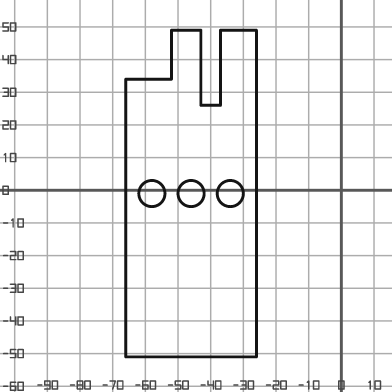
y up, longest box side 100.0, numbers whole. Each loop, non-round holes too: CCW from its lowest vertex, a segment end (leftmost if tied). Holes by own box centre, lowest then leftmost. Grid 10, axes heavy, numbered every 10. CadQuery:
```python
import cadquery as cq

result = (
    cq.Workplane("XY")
    .moveTo(-66.0, -51.0)
    .lineTo(-26.0, -51.0)
    .lineTo(-26.0, 49.0)
    .lineTo(-37.0, 49.0)
    .lineTo(-37.0, 26.0)
    .lineTo(-43.0, 26.0)
    .lineTo(-43.0, 49.0)
    .lineTo(-52.0, 49.0)
    .lineTo(-52.0, 34.0)
    .lineTo(-66.0, 34.0)
    .close()
    .moveTo(-58.0, -1.0)
    .circle(4.0)
    .moveTo(-46.0, -1.0)
    .circle(4.0)
    .moveTo(-34.0, -1.0)
    .circle(4.0)
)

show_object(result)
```